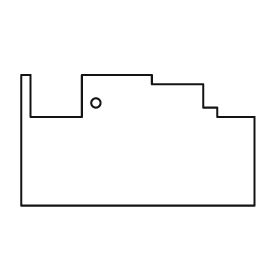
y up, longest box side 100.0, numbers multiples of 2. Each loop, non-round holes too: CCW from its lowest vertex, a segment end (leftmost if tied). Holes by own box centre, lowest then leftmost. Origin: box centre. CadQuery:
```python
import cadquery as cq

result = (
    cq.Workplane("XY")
    .moveTo(-50.0, -28.0)
    .lineTo(50.0, -28.0)
    .lineTo(50.0, 10.0)
    .lineTo(34.0, 10.0)
    .lineTo(34.0, 14.0)
    .lineTo(28.0, 14.0)
    .lineTo(28.0, 24.0)
    .lineTo(6.0, 24.0)
    .lineTo(6.0, 28.0)
    .lineTo(-24.0, 28.0)
    .lineTo(-24.0, 10.0)
    .lineTo(-46.0, 10.0)
    .lineTo(-46.0, 28.0)
    .lineTo(-50.0, 28.0)
    .close()
    .moveTo(-18.0, 16.0)
    .circle(2.0)
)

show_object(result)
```